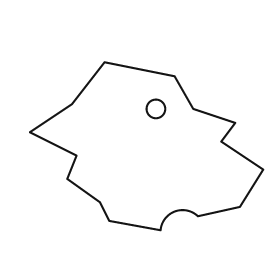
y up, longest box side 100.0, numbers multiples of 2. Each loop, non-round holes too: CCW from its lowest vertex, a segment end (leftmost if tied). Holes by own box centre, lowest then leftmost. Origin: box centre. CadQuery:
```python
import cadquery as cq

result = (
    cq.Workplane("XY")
    .moveTo(6.0, -36.0)
    .threePointArc((12.0, -28.0), (22.0, -30.0))
    .lineTo(40.0, -26.0)
    .lineTo(50.0, -10.0)
    .lineTo(32.0, 2.0)
    .lineTo(38.0, 10.0)
    .lineTo(20.0, 16.0)
    .lineTo(12.0, 30.0)
    .lineTo(-18.0, 36.0)
    .lineTo(-32.0, 18.0)
    .lineTo(-50.0, 6.0)
    .lineTo(-30.0, -4.0)
    .lineTo(-34.0, -14.0)
    .lineTo(-20.0, -24.0)
    .lineTo(-16.0, -32.0)
    .close()
    .moveTo(4.0, 16.0)
    .circle(4.0)
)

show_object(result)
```